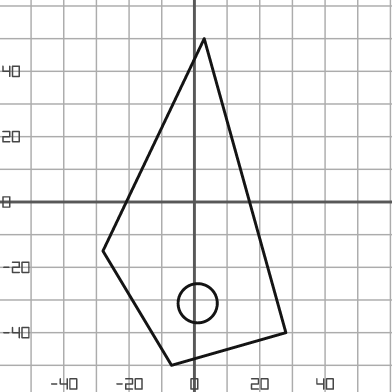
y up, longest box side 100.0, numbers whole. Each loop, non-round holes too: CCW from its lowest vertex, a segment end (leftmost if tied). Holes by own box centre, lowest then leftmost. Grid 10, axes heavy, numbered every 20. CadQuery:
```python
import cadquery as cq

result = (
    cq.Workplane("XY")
    .moveTo(-7.0, -50.0)
    .lineTo(28.0, -40.0)
    .lineTo(3.0, 50.0)
    .lineTo(-28.0, -15.0)
    .close()
    .moveTo(1.0, -31.0)
    .circle(6.0)
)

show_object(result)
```